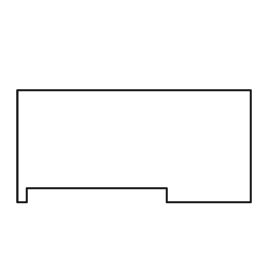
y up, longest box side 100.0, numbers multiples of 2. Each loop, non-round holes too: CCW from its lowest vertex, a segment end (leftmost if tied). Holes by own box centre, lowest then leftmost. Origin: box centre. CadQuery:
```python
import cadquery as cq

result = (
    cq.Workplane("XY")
    .moveTo(-50.0, -24.0)
    .lineTo(-46.0, -24.0)
    .lineTo(-46.0, -18.0)
    .lineTo(14.0, -18.0)
    .lineTo(14.0, -24.0)
    .lineTo(50.0, -24.0)
    .lineTo(50.0, 24.0)
    .lineTo(-50.0, 24.0)
    .close()
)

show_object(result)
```